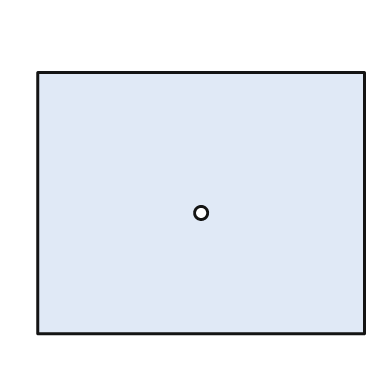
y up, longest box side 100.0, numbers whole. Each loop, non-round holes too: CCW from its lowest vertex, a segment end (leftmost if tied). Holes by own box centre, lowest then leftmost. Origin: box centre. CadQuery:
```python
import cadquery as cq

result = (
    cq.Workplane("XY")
    .moveTo(-50.0, -40.0)
    .lineTo(50.0, -40.0)
    .lineTo(50.0, 40.0)
    .lineTo(-50.0, 40.0)
    .close()
    .moveTo(0.0, -3.0)
    .circle(2.0)
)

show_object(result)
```